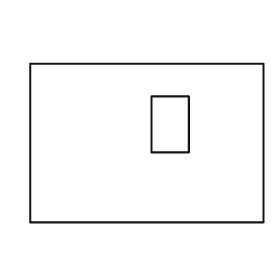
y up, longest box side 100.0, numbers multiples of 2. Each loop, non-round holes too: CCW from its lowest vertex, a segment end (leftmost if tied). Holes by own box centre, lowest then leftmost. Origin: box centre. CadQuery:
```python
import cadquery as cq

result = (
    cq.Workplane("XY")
    .moveTo(-50.0, -34.0)
    .lineTo(50.0, -34.0)
    .lineTo(50.0, 34.0)
    .lineTo(-50.0, 34.0)
    .close()
    .moveTo(2.0, -4.0)
    .lineTo(18.0, -4.0)
    .lineTo(18.0, 20.0)
    .lineTo(2.0, 20.0)
    .close()
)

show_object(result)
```